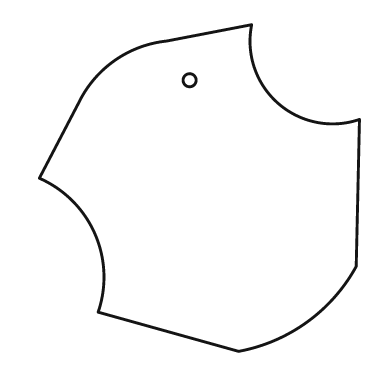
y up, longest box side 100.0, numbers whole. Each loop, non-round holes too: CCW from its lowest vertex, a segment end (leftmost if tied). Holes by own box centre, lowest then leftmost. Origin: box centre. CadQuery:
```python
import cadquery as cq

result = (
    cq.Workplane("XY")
    .moveTo(12.0, -50.0)
    .threePointArc((33.0, -41.0), (48.0, -24.0))
    .lineTo(49.0, 21.0)
    .threePointArc((24.0, 26.0), (16.0, 50.0))
    .lineTo(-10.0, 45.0)
    .threePointArc((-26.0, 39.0), (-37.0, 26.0))
    .lineTo(-49.0, 3.0)
    .threePointArc((-32.0, -14.0), (-31.0, -38.0))
    .close()
    .moveTo(-3.0, 33.0)
    .circle(2.0)
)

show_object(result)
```